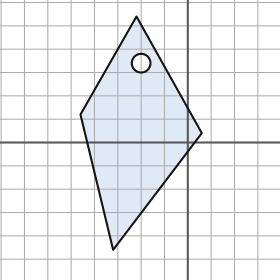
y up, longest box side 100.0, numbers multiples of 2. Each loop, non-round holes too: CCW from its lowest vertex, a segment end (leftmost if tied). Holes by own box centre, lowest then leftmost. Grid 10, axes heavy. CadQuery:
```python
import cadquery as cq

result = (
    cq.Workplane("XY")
    .moveTo(-32.0, -46.0)
    .lineTo(6.0, 4.0)
    .lineTo(-22.0, 54.0)
    .lineTo(-46.0, 12.0)
    .close()
    .moveTo(-20.0, 34.0)
    .circle(4.0)
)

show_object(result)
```